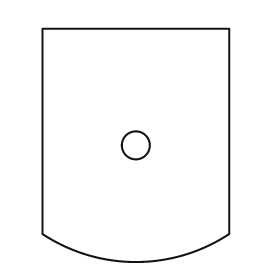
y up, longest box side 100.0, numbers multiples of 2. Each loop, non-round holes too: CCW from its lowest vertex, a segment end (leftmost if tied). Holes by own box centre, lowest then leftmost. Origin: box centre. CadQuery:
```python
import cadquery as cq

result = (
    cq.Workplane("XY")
    .moveTo(-40.0, -38.0)
    .threePointArc((0.0, -50.0), (40.0, -38.0))
    .lineTo(40.0, 50.0)
    .lineTo(-40.0, 50.0)
    .close()
    .moveTo(0.0, 0.0)
    .circle(6.0)
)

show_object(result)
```